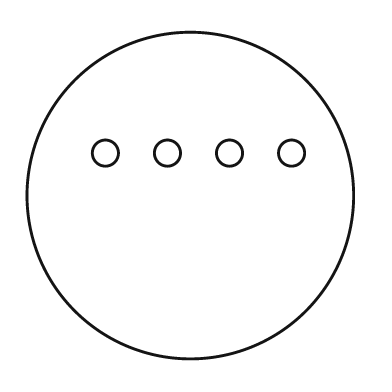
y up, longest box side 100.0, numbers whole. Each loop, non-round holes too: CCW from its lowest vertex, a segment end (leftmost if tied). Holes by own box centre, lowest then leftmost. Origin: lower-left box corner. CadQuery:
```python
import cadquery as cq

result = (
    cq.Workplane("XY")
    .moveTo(50.0, 50.0)
    .circle(50.0)
    .moveTo(24.0, 63.0)
    .circle(4.0)
    .moveTo(43.0, 63.0)
    .circle(4.0)
    .moveTo(62.0, 63.0)
    .circle(4.0)
    .moveTo(81.0, 63.0)
    .circle(4.0)
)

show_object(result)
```